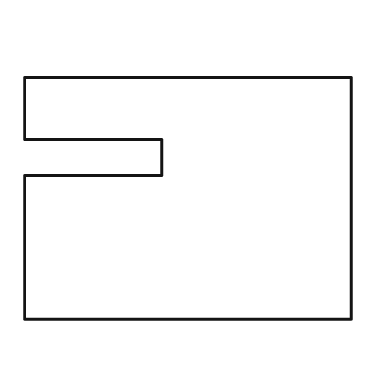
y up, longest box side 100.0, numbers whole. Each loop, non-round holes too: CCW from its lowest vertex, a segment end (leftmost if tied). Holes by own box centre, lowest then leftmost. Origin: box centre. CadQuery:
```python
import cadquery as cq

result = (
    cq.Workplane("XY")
    .moveTo(-50.0, -37.0)
    .lineTo(50.0, -37.0)
    .lineTo(50.0, 37.0)
    .lineTo(-50.0, 37.0)
    .lineTo(-50.0, 18.0)
    .lineTo(-8.0, 18.0)
    .lineTo(-8.0, 7.0)
    .lineTo(-50.0, 7.0)
    .close()
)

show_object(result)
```